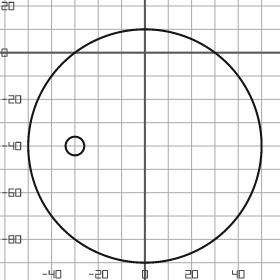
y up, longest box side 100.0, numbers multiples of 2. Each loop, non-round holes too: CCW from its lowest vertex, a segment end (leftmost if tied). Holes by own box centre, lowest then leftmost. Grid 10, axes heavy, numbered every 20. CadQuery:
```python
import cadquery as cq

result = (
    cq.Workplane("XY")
    .moveTo(0.0, -40.0)
    .circle(50.0)
    .moveTo(-30.0, -40.0)
    .circle(4.0)
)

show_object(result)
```